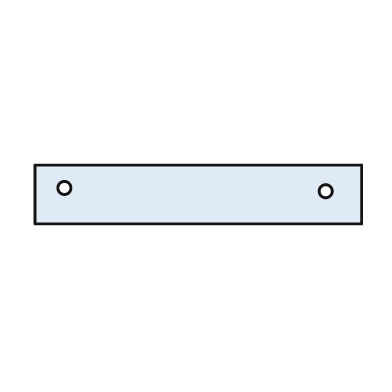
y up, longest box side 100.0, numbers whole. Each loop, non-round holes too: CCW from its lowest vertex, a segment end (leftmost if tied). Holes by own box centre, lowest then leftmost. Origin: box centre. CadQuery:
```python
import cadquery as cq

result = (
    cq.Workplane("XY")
    .moveTo(-50.0, -9.0)
    .lineTo(50.0, -9.0)
    .lineTo(50.0, 9.0)
    .lineTo(-50.0, 9.0)
    .close()
    .moveTo(39.0, 1.0)
    .circle(2.0)
    .moveTo(-41.0, 2.0)
    .circle(2.0)
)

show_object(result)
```